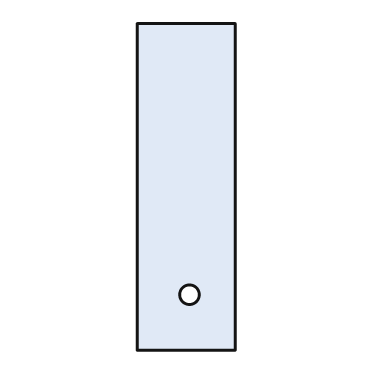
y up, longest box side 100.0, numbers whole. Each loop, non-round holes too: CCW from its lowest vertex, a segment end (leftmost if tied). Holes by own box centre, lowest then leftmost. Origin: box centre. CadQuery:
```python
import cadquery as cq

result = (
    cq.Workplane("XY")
    .moveTo(-15.0, -50.0)
    .lineTo(15.0, -50.0)
    .lineTo(15.0, 50.0)
    .lineTo(-15.0, 50.0)
    .close()
    .moveTo(1.0, -33.0)
    .circle(3.0)
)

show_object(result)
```